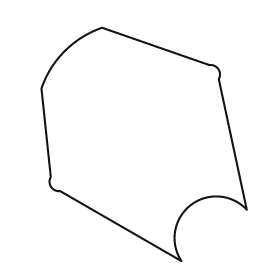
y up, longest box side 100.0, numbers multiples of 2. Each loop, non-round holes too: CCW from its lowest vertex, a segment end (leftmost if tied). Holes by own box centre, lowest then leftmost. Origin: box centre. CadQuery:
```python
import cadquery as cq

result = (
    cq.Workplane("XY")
    .moveTo(16.0, -50.0)
    .threePointArc((20.0, -26.0), (44.0, -28.0))
    .lineTo(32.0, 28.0)
    .threePointArc((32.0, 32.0), (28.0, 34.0))
    .lineTo(-18.0, 50.0)
    .threePointArc((-34.0, 40.0), (-44.0, 24.0))
    .lineTo(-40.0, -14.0)
    .threePointArc((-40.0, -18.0), (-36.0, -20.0))
    .close()
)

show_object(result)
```